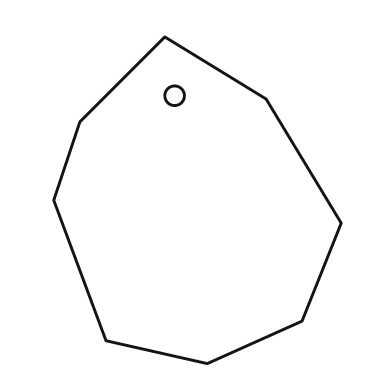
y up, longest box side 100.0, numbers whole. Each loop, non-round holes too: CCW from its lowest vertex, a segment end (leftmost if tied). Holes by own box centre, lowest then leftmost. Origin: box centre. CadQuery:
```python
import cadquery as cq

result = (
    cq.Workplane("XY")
    .moveTo(3.0, -50.0)
    .lineTo(32.0, -37.0)
    .lineTo(44.0, -7.0)
    .lineTo(21.0, 31.0)
    .lineTo(-10.0, 50.0)
    .lineTo(-36.0, 24.0)
    .lineTo(-44.0, 0.0)
    .lineTo(-28.0, -43.0)
    .close()
    .moveTo(-7.0, 32.0)
    .circle(3.0)
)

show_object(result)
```